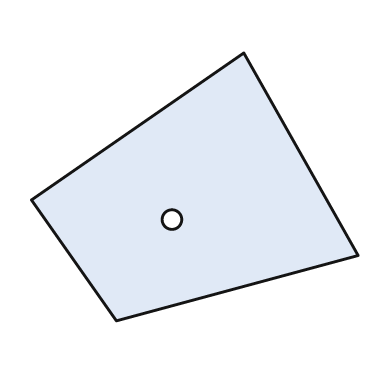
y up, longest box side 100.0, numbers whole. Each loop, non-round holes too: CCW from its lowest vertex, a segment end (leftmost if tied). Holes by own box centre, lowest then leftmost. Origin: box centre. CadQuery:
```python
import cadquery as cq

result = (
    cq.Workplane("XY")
    .moveTo(-24.0, -41.0)
    .lineTo(50.0, -21.0)
    .lineTo(15.0, 41.0)
    .lineTo(-50.0, -4.0)
    .close()
    .moveTo(-7.0, -10.0)
    .circle(3.0)
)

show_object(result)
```